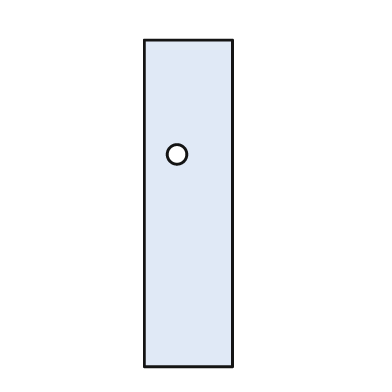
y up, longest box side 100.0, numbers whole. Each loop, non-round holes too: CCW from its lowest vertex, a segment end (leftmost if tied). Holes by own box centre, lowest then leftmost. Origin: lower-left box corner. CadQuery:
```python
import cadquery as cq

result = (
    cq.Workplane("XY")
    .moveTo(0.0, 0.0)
    .lineTo(27.0, 0.0)
    .lineTo(27.0, 100.0)
    .lineTo(0.0, 100.0)
    .close()
    .moveTo(10.0, 65.0)
    .circle(3.0)
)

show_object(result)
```